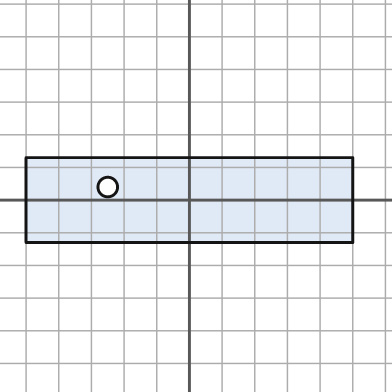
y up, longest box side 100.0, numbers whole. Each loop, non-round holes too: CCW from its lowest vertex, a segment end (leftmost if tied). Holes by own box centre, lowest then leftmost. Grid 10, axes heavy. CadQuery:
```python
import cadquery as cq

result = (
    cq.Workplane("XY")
    .moveTo(-50.0, -13.0)
    .lineTo(50.0, -13.0)
    .lineTo(50.0, 13.0)
    .lineTo(-50.0, 13.0)
    .close()
    .moveTo(-25.0, 4.0)
    .circle(3.0)
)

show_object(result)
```